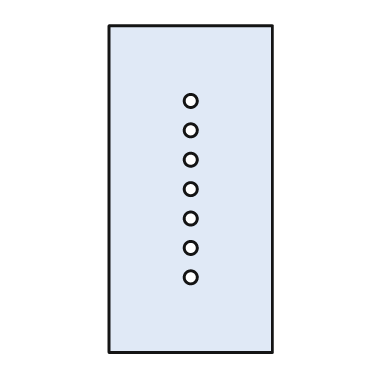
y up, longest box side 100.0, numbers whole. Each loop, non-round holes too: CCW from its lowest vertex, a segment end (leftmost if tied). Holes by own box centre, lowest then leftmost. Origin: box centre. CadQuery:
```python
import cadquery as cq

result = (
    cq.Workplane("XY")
    .moveTo(-25.0, -50.0)
    .lineTo(25.0, -50.0)
    .lineTo(25.0, 50.0)
    .lineTo(-25.0, 50.0)
    .close()
    .moveTo(0.0, -27.0)
    .circle(2.0)
    .moveTo(0.0, -18.0)
    .circle(2.0)
    .moveTo(0.0, -9.0)
    .circle(2.0)
    .moveTo(0.0, 0.0)
    .circle(2.0)
    .moveTo(0.0, 9.0)
    .circle(2.0)
    .moveTo(0.0, 18.0)
    .circle(2.0)
    .moveTo(0.0, 27.0)
    .circle(2.0)
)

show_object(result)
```